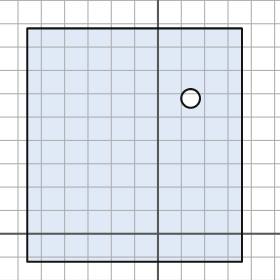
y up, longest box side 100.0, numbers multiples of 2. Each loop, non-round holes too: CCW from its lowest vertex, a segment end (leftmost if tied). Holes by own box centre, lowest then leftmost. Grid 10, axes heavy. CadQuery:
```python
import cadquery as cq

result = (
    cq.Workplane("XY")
    .moveTo(-56.0, -12.0)
    .lineTo(36.0, -12.0)
    .lineTo(36.0, 88.0)
    .lineTo(-56.0, 88.0)
    .close()
    .moveTo(14.0, 58.0)
    .circle(4.0)
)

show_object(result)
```